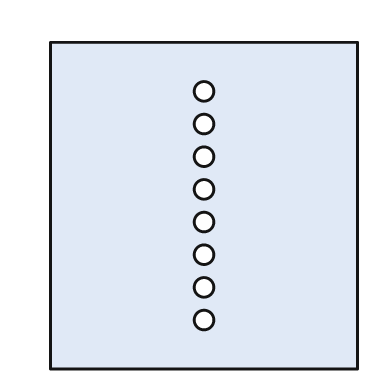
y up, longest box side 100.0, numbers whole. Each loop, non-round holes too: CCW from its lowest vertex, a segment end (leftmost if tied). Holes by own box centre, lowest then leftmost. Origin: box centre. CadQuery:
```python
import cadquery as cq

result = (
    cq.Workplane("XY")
    .moveTo(-47.0, -50.0)
    .lineTo(47.0, -50.0)
    .lineTo(47.0, 50.0)
    .lineTo(-47.0, 50.0)
    .close()
    .moveTo(0.0, -35.0)
    .circle(3.0)
    .moveTo(0.0, -25.0)
    .circle(3.0)
    .moveTo(0.0, -15.0)
    .circle(3.0)
    .moveTo(0.0, -5.0)
    .circle(3.0)
    .moveTo(0.0, 5.0)
    .circle(3.0)
    .moveTo(0.0, 15.0)
    .circle(3.0)
    .moveTo(0.0, 25.0)
    .circle(3.0)
    .moveTo(0.0, 35.0)
    .circle(3.0)
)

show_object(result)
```